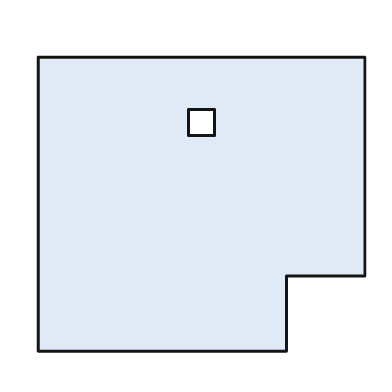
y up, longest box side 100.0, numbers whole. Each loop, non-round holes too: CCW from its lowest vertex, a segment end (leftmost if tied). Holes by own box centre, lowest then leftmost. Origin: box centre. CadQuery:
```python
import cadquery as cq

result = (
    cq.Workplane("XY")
    .moveTo(-50.0, -45.0)
    .lineTo(26.0, -45.0)
    .lineTo(26.0, -22.0)
    .lineTo(50.0, -22.0)
    .lineTo(50.0, 45.0)
    .lineTo(-50.0, 45.0)
    .close()
    .moveTo(-4.0, 21.0)
    .lineTo(4.0, 21.0)
    .lineTo(4.0, 29.0)
    .lineTo(-4.0, 29.0)
    .close()
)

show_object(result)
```